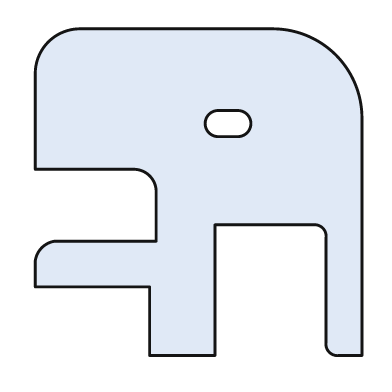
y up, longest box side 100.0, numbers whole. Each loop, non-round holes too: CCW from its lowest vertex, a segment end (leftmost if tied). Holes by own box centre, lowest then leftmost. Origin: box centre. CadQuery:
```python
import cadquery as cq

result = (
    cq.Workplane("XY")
    .moveTo(-15.0, -50.0)
    .lineTo(5.0, -50.0)
    .lineTo(5.0, -10.0)
    .lineTo(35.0, -10.0)
    .threePointArc((38.0, -11.0), (39.0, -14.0))
    .lineTo(39.0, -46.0)
    .threePointArc((40.0, -49.0), (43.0, -50.0))
    .lineTo(50.0, -50.0)
    .lineTo(50.0, 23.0)
    .threePointArc((42.0, 42.0), (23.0, 50.0))
    .lineTo(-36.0, 50.0)
    .threePointArc((-46.0, 46.0), (-50.0, 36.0))
    .lineTo(-50.0, 7.0)
    .lineTo(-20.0, 7.0)
    .threePointArc((-15.0, 5.0), (-13.0, 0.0))
    .lineTo(-13.0, -15.0)
    .lineTo(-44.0, -15.0)
    .threePointArc((-48.0, -17.0), (-50.0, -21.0))
    .lineTo(-50.0, -29.0)
    .lineTo(-15.0, -29.0)
    .close()
    .moveTo(6.0, 17.0)
    .lineTo(12.0, 17.0)
    .threePointArc((16.0, 21.0), (12.0, 25.0))
    .lineTo(6.0, 25.0)
    .threePointArc((2.0, 21.0), (6.0, 17.0))
    .close()
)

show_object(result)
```